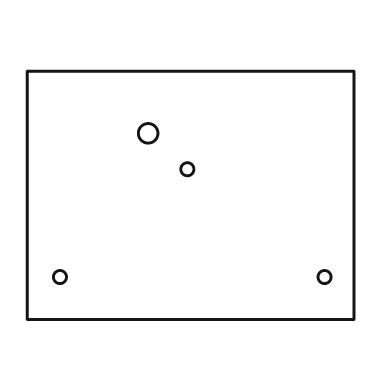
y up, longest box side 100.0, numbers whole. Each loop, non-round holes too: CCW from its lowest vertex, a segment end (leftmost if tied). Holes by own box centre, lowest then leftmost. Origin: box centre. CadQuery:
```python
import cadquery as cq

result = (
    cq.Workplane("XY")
    .moveTo(-50.0, -38.0)
    .lineTo(50.0, -38.0)
    .lineTo(50.0, 38.0)
    .lineTo(-50.0, 38.0)
    .close()
    .moveTo(-40.0, -25.0)
    .circle(2.0)
    .moveTo(41.0, -25.0)
    .circle(2.0)
    .moveTo(-1.0, 8.0)
    .circle(2.0)
    .moveTo(-13.0, 19.0)
    .circle(3.0)
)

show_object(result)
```